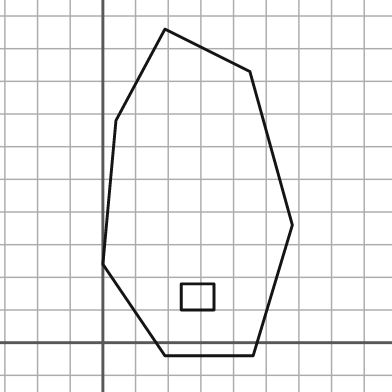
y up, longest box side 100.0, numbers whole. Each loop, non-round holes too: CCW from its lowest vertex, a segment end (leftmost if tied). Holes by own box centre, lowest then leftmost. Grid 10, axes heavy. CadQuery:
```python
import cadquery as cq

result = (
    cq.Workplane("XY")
    .moveTo(19.0, -4.0)
    .lineTo(46.0, -4.0)
    .lineTo(58.0, 36.0)
    .lineTo(45.0, 83.0)
    .lineTo(19.0, 96.0)
    .lineTo(4.0, 68.0)
    .lineTo(0.0, 24.0)
    .close()
    .moveTo(24.0, 10.0)
    .lineTo(34.0, 10.0)
    .lineTo(34.0, 18.0)
    .lineTo(24.0, 18.0)
    .close()
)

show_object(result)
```